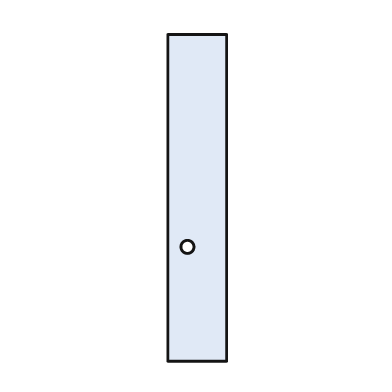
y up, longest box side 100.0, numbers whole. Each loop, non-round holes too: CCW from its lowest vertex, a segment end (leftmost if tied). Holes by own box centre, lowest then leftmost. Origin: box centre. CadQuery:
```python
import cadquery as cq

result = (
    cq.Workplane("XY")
    .moveTo(-9.0, -50.0)
    .lineTo(9.0, -50.0)
    .lineTo(9.0, 50.0)
    .lineTo(-9.0, 50.0)
    .close()
    .moveTo(-3.0, -15.0)
    .circle(2.0)
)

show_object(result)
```